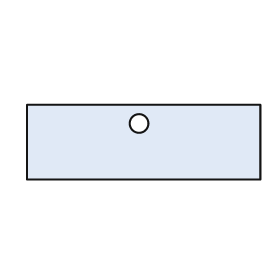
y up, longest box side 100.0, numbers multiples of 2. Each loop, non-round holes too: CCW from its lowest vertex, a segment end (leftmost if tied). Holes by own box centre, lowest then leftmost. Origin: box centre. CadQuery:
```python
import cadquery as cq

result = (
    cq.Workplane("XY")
    .moveTo(-50.0, -16.0)
    .lineTo(50.0, -16.0)
    .lineTo(50.0, 16.0)
    .lineTo(-50.0, 16.0)
    .close()
    .moveTo(-2.0, 8.0)
    .circle(4.0)
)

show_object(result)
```